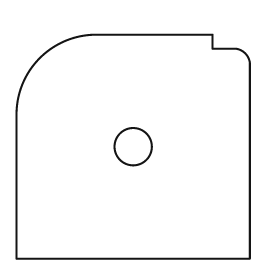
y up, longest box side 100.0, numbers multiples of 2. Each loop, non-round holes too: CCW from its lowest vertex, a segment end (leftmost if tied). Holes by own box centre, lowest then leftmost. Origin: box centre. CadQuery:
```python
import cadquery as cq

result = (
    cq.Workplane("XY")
    .moveTo(-50.0, -48.0)
    .lineTo(50.0, -48.0)
    .lineTo(50.0, 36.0)
    .threePointArc((48.0, 40.0), (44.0, 42.0))
    .lineTo(34.0, 42.0)
    .lineTo(34.0, 48.0)
    .lineTo(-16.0, 48.0)
    .threePointArc((-40.0, 38.0), (-50.0, 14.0))
    .close()
    .moveTo(0.0, 0.0)
    .circle(8.0)
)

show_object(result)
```